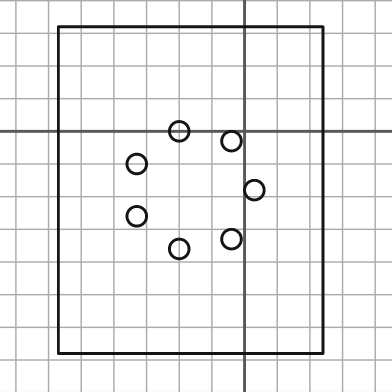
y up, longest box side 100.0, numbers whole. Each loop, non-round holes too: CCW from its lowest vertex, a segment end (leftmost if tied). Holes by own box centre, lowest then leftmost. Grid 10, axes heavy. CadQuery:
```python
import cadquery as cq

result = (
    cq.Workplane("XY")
    .moveTo(-57.0, -68.0)
    .lineTo(24.0, -68.0)
    .lineTo(24.0, 32.0)
    .lineTo(-57.0, 32.0)
    .close()
    .moveTo(-20.0, -36.0)
    .circle(3.0)
    .moveTo(-4.0, -33.0)
    .circle(3.0)
    .moveTo(-33.0, -26.0)
    .circle(3.0)
    .moveTo(3.0, -18.0)
    .circle(3.0)
    .moveTo(-33.0, -10.0)
    .circle(3.0)
    .moveTo(-4.0, -3.0)
    .circle(3.0)
    .moveTo(-20.0, 0.0)
    .circle(3.0)
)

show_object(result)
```